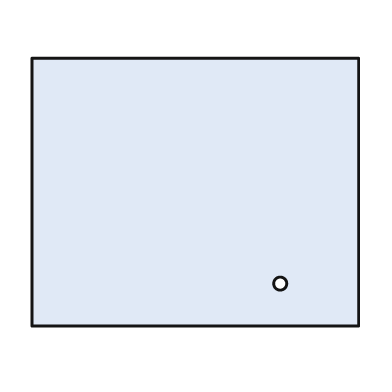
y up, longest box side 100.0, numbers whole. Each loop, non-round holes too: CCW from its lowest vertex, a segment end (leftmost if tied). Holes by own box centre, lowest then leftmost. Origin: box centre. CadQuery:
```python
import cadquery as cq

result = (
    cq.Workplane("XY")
    .moveTo(-50.0, -41.0)
    .lineTo(50.0, -41.0)
    .lineTo(50.0, 41.0)
    .lineTo(-50.0, 41.0)
    .close()
    .moveTo(26.0, -28.0)
    .circle(2.0)
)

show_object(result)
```